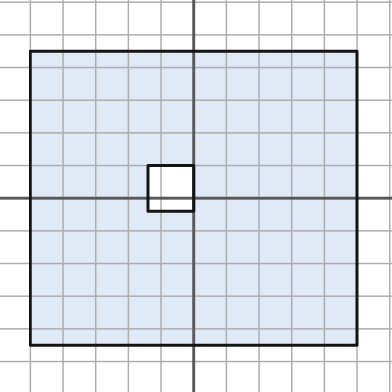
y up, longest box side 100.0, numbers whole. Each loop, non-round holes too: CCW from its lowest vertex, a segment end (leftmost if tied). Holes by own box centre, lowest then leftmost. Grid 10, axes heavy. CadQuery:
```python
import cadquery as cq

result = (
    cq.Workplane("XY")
    .moveTo(-50.0, -45.0)
    .lineTo(50.0, -45.0)
    .lineTo(50.0, 45.0)
    .lineTo(-50.0, 45.0)
    .close()
    .moveTo(-14.0, -4.0)
    .lineTo(0.0, -4.0)
    .lineTo(0.0, 10.0)
    .lineTo(-14.0, 10.0)
    .close()
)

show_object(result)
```